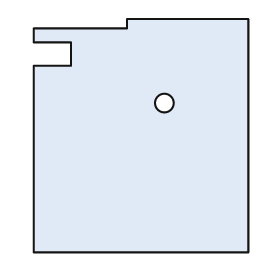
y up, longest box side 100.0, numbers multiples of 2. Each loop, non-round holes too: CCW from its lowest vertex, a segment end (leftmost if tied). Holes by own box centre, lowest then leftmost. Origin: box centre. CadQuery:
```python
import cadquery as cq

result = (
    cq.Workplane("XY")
    .moveTo(-46.0, -50.0)
    .lineTo(46.0, -50.0)
    .lineTo(46.0, 50.0)
    .lineTo(-6.0, 50.0)
    .lineTo(-6.0, 46.0)
    .lineTo(-46.0, 46.0)
    .lineTo(-46.0, 40.0)
    .lineTo(-30.0, 40.0)
    .lineTo(-30.0, 30.0)
    .lineTo(-46.0, 30.0)
    .close()
    .moveTo(10.0, 14.0)
    .circle(4.0)
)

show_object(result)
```